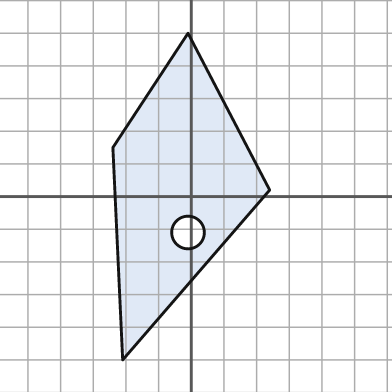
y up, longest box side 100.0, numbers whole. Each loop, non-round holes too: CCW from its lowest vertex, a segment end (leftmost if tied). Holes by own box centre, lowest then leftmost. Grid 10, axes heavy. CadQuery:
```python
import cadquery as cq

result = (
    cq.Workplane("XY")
    .moveTo(-21.0, -50.0)
    .lineTo(24.0, 2.0)
    .lineTo(-1.0, 50.0)
    .lineTo(-24.0, 15.0)
    .close()
    .moveTo(-1.0, -11.0)
    .circle(5.0)
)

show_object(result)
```